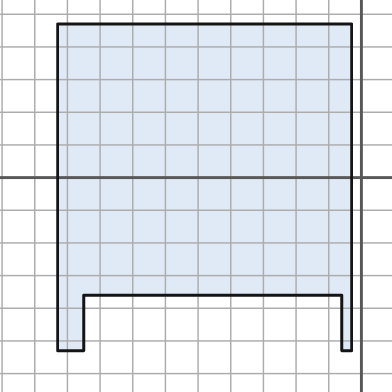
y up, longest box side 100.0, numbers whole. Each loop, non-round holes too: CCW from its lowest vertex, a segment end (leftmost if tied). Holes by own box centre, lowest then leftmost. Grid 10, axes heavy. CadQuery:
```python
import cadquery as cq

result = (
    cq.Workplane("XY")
    .moveTo(-93.0, -53.0)
    .lineTo(-85.0, -53.0)
    .lineTo(-85.0, -36.0)
    .lineTo(-6.0, -36.0)
    .lineTo(-6.0, -53.0)
    .lineTo(-3.0, -53.0)
    .lineTo(-3.0, 47.0)
    .lineTo(-93.0, 47.0)
    .close()
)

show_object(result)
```